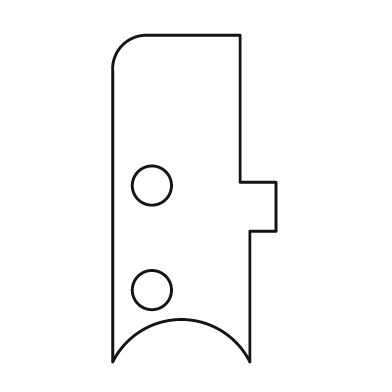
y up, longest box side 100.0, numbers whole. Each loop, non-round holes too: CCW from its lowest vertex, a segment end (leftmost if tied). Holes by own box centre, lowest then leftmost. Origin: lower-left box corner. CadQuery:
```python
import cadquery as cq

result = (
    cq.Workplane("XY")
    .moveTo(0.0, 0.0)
    .threePointArc((21.0, 13.0), (42.0, 0.0))
    .lineTo(42.0, 40.0)
    .lineTo(50.0, 40.0)
    .lineTo(50.0, 55.0)
    .lineTo(39.0, 55.0)
    .lineTo(39.0, 100.0)
    .lineTo(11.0, 100.0)
    .threePointArc((3.0, 97.0), (0.0, 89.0))
    .close()
    .moveTo(12.0, 22.0)
    .circle(6.0)
    .moveTo(12.0, 54.0)
    .circle(6.0)
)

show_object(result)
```